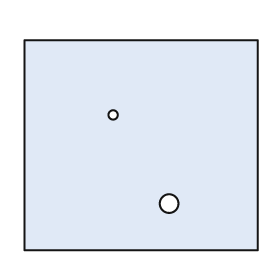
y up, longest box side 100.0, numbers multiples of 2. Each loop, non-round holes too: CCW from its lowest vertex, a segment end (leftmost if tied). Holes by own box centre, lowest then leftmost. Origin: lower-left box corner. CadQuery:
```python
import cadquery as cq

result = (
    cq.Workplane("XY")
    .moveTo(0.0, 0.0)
    .lineTo(100.0, 0.0)
    .lineTo(100.0, 90.0)
    .lineTo(0.0, 90.0)
    .close()
    .moveTo(62.0, 20.0)
    .circle(4.0)
    .moveTo(38.0, 58.0)
    .circle(2.0)
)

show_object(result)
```